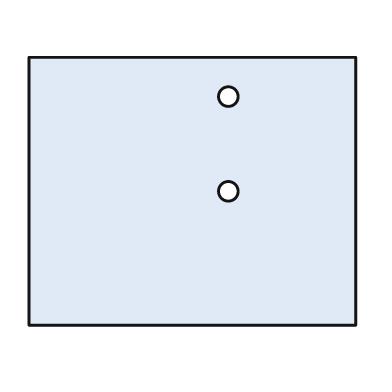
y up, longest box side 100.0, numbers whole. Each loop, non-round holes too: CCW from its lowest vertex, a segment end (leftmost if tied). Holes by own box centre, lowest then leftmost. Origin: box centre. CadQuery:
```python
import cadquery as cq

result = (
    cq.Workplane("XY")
    .moveTo(-50.0, -41.0)
    .lineTo(50.0, -41.0)
    .lineTo(50.0, 41.0)
    .lineTo(-50.0, 41.0)
    .close()
    .moveTo(11.0, 0.0)
    .circle(3.0)
    .moveTo(11.0, 29.0)
    .circle(3.0)
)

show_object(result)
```